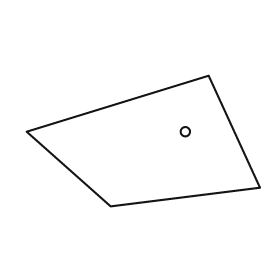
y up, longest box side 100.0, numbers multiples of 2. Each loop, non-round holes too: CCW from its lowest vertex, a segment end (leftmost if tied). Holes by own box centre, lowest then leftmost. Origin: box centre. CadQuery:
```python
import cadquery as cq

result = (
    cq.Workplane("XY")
    .moveTo(-14.0, -28.0)
    .lineTo(50.0, -20.0)
    .lineTo(28.0, 28.0)
    .lineTo(-50.0, 4.0)
    .close()
    .moveTo(18.0, 4.0)
    .circle(2.0)
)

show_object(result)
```